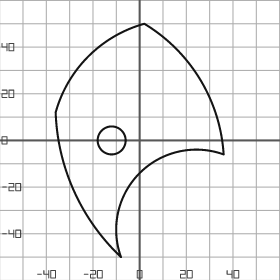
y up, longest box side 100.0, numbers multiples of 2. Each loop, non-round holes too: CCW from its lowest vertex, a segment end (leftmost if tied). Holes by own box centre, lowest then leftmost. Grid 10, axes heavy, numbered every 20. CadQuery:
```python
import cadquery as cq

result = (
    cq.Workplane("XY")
    .moveTo(-8.0, -50.0)
    .threePointArc((0.0, -14.0), (36.0, -6.0))
    .threePointArc((26.0, 26.0), (2.0, 50.0))
    .threePointArc((-22.0, 36.0), (-36.0, 12.0))
    .threePointArc((-28.0, -22.0), (-8.0, -50.0))
    .close()
    .moveTo(-12.0, 0.0)
    .circle(6.0)
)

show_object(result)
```